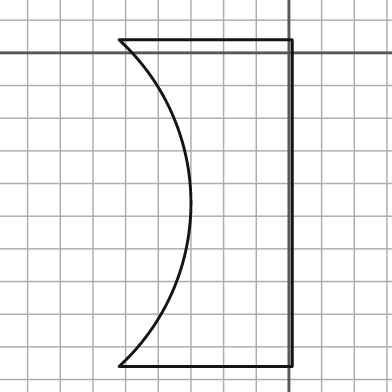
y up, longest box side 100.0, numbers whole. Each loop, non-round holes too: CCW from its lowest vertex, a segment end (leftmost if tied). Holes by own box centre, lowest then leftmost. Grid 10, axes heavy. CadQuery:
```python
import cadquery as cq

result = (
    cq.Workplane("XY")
    .moveTo(-52.0, -96.0)
    .lineTo(1.0, -96.0)
    .lineTo(1.0, 4.0)
    .lineTo(-52.0, 4.0)
    .threePointArc((-30.0, -46.0), (-52.0, -96.0))
    .close()
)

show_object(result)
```